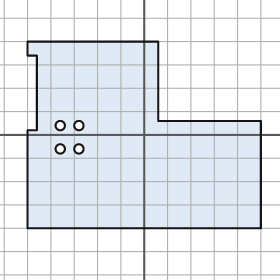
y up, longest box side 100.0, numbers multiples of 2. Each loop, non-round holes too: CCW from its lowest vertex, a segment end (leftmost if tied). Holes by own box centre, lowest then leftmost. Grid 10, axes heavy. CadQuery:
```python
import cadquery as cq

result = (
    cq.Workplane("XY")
    .moveTo(-50.0, -40.0)
    .lineTo(50.0, -40.0)
    .lineTo(50.0, 6.0)
    .lineTo(6.0, 6.0)
    .lineTo(6.0, 40.0)
    .lineTo(-50.0, 40.0)
    .lineTo(-50.0, 34.0)
    .lineTo(-46.0, 34.0)
    .lineTo(-46.0, 2.0)
    .lineTo(-50.0, 2.0)
    .close()
    .moveTo(-36.0, -6.0)
    .circle(2.0)
    .moveTo(-28.0, -6.0)
    .circle(2.0)
    .moveTo(-36.0, 4.0)
    .circle(2.0)
    .moveTo(-28.0, 4.0)
    .circle(2.0)
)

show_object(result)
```